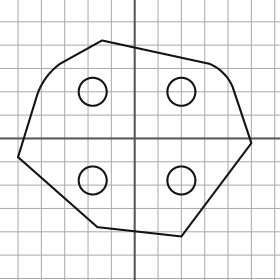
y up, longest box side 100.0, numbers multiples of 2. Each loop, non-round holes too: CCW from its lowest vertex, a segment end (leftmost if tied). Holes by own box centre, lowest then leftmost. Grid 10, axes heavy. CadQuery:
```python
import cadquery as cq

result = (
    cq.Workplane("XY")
    .moveTo(20.0, -42.0)
    .lineTo(50.0, -2.0)
    .lineTo(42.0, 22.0)
    .threePointArc((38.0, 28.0), (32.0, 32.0))
    .lineTo(-14.0, 42.0)
    .lineTo(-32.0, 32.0)
    .threePointArc((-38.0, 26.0), (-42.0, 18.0))
    .lineTo(-50.0, -8.0)
    .lineTo(-16.0, -38.0)
    .close()
    .moveTo(-18.0, -18.0)
    .circle(6.0)
    .moveTo(20.0, -18.0)
    .circle(6.0)
    .moveTo(-18.0, 20.0)
    .circle(6.0)
    .moveTo(20.0, 20.0)
    .circle(6.0)
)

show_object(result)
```